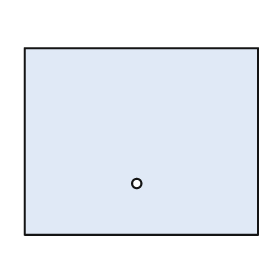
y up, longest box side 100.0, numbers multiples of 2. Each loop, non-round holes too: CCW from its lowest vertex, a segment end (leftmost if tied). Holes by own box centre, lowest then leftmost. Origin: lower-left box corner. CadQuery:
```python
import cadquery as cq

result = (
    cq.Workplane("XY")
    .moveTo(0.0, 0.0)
    .lineTo(100.0, 0.0)
    .lineTo(100.0, 80.0)
    .lineTo(0.0, 80.0)
    .close()
    .moveTo(48.0, 22.0)
    .circle(2.0)
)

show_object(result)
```